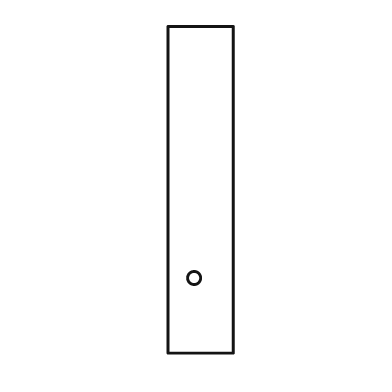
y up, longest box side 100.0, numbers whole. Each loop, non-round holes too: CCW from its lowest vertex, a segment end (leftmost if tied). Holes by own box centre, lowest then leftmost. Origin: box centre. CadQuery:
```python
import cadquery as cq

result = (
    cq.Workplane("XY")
    .moveTo(-10.0, -50.0)
    .lineTo(10.0, -50.0)
    .lineTo(10.0, 50.0)
    .lineTo(-10.0, 50.0)
    .close()
    .moveTo(-2.0, -27.0)
    .circle(2.0)
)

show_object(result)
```